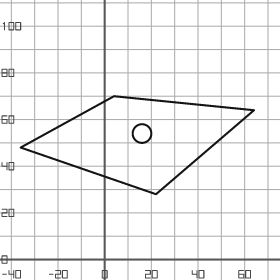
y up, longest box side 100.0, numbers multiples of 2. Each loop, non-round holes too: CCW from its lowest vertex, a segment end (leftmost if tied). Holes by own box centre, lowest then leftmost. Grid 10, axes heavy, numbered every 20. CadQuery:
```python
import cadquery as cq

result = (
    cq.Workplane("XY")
    .moveTo(22.0, 28.0)
    .lineTo(64.0, 64.0)
    .lineTo(4.0, 70.0)
    .lineTo(-36.0, 48.0)
    .close()
    .moveTo(16.0, 54.0)
    .circle(4.0)
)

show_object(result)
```